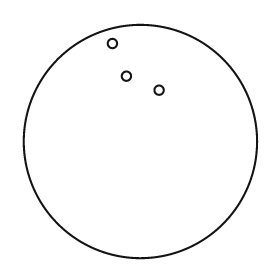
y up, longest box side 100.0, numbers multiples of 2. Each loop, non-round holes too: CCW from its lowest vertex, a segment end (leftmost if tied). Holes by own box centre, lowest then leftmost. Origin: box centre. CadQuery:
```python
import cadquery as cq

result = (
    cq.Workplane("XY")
    .moveTo(0.0, 0.0)
    .circle(50.0)
    .moveTo(8.0, 22.0)
    .circle(2.0)
    .moveTo(-6.0, 28.0)
    .circle(2.0)
    .moveTo(-12.0, 42.0)
    .circle(2.0)
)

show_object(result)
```